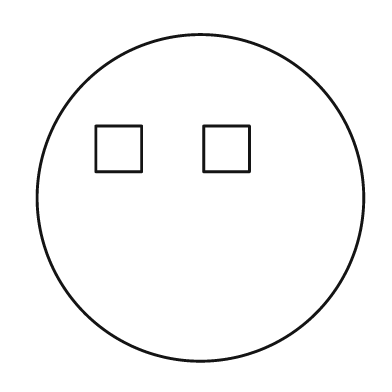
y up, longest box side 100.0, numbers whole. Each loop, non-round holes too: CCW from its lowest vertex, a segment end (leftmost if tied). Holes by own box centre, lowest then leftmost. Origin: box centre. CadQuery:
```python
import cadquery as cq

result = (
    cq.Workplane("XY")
    .moveTo(0.0, 0.0)
    .circle(50.0)
    .moveTo(-32.0, 8.0)
    .lineTo(-18.0, 8.0)
    .lineTo(-18.0, 22.0)
    .lineTo(-32.0, 22.0)
    .close()
    .moveTo(1.0, 8.0)
    .lineTo(15.0, 8.0)
    .lineTo(15.0, 22.0)
    .lineTo(1.0, 22.0)
    .close()
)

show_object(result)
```